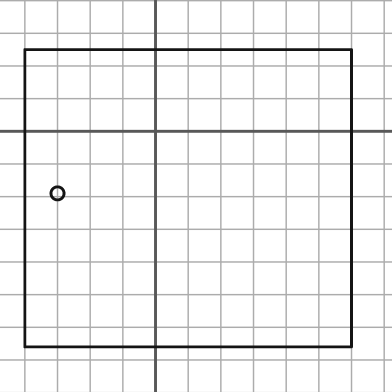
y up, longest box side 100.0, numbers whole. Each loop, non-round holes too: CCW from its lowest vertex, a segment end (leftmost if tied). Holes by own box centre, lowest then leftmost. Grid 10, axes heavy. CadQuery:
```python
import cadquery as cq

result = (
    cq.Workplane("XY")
    .moveTo(-40.0, -66.0)
    .lineTo(60.0, -66.0)
    .lineTo(60.0, 25.0)
    .lineTo(-40.0, 25.0)
    .close()
    .moveTo(-30.0, -19.0)
    .circle(2.0)
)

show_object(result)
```